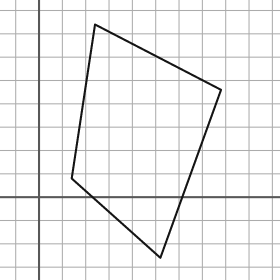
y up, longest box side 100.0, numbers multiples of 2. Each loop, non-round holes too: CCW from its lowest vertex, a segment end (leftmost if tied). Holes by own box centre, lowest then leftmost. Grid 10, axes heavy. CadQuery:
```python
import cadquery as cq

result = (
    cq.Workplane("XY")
    .moveTo(52.0, -26.0)
    .lineTo(78.0, 46.0)
    .lineTo(24.0, 74.0)
    .lineTo(14.0, 8.0)
    .close()
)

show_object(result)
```